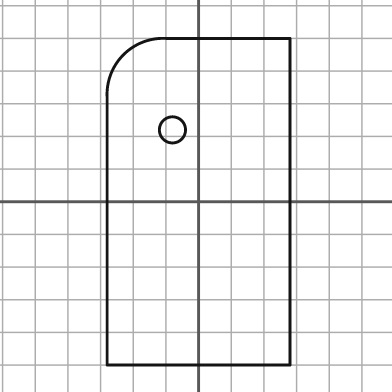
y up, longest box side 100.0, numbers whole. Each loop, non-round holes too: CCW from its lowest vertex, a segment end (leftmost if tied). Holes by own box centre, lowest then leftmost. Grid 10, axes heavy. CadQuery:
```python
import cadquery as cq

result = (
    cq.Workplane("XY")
    .moveTo(-28.0, -50.0)
    .lineTo(28.0, -50.0)
    .lineTo(28.0, 50.0)
    .lineTo(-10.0, 50.0)
    .threePointArc((-23.0, 45.0), (-28.0, 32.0))
    .close()
    .moveTo(-8.0, 22.0)
    .circle(4.0)
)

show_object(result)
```